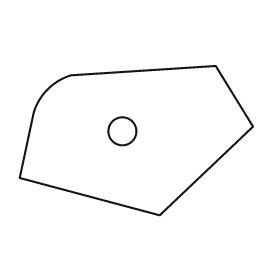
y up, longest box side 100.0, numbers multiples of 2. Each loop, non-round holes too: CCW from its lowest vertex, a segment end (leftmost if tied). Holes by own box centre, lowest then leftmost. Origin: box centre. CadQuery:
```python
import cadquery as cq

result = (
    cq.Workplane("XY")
    .moveTo(10.0, -32.0)
    .lineTo(50.0, 6.0)
    .lineTo(34.0, 32.0)
    .lineTo(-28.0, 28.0)
    .threePointArc((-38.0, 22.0), (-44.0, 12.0))
    .lineTo(-50.0, -16.0)
    .close()
    .moveTo(-6.0, 4.0)
    .circle(6.0)
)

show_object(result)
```